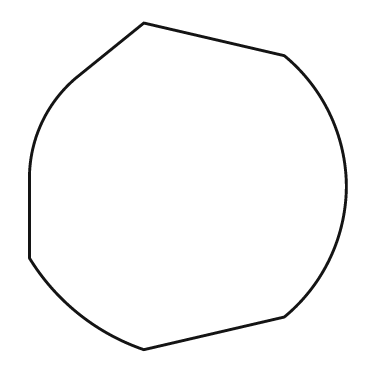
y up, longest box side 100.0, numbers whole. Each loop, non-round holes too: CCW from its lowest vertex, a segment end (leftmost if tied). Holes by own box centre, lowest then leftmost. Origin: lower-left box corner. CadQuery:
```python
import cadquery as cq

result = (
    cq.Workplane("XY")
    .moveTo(35.0, 0.0)
    .lineTo(78.0, 10.0)
    .threePointArc((92.0, 28.0), (97.0, 50.0))
    .threePointArc((92.0, 72.0), (78.0, 90.0))
    .lineTo(35.0, 100.0)
    .lineTo(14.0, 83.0)
    .threePointArc((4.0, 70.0), (0.0, 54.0))
    .lineTo(0.0, 28.0)
    .threePointArc((15.0, 11.0), (35.0, 0.0))
    .close()
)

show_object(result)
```